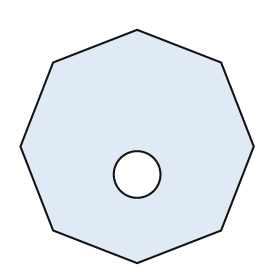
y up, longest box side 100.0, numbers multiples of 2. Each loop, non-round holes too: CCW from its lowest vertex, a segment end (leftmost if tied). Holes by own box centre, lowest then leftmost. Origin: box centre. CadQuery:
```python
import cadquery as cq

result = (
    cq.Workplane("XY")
    .moveTo(0.0, -50.0)
    .lineTo(36.0, -36.0)
    .lineTo(50.0, 0.0)
    .lineTo(36.0, 36.0)
    .lineTo(0.0, 50.0)
    .lineTo(-36.0, 36.0)
    .lineTo(-50.0, 0.0)
    .lineTo(-36.0, -36.0)
    .close()
    .moveTo(0.0, -12.0)
    .circle(10.0)
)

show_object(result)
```